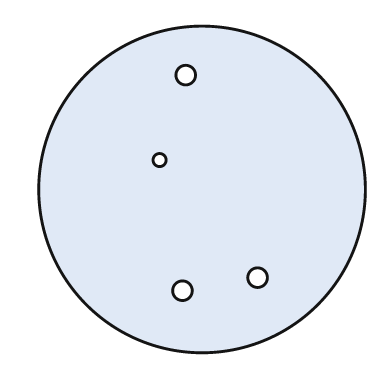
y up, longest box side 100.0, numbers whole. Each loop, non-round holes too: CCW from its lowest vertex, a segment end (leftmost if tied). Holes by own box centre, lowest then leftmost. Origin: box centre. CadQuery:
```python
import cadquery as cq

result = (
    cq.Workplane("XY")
    .moveTo(0.0, 0.0)
    .circle(50.0)
    .moveTo(-6.0, -31.0)
    .circle(3.0)
    .moveTo(17.0, -27.0)
    .circle(3.0)
    .moveTo(-13.0, 9.0)
    .circle(2.0)
    .moveTo(-5.0, 35.0)
    .circle(3.0)
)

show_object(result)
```